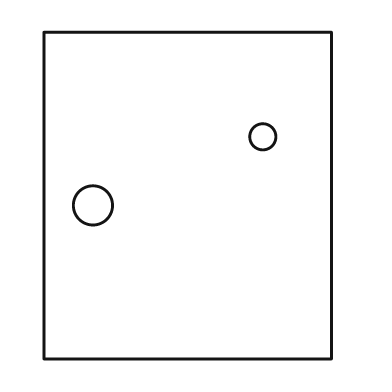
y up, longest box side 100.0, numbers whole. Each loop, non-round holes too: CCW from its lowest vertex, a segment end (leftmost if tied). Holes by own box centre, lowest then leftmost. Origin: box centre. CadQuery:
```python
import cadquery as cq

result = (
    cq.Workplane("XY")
    .moveTo(-44.0, -50.0)
    .lineTo(44.0, -50.0)
    .lineTo(44.0, 50.0)
    .lineTo(-44.0, 50.0)
    .close()
    .moveTo(-29.0, -3.0)
    .circle(6.0)
    .moveTo(23.0, 18.0)
    .circle(4.0)
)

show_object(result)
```